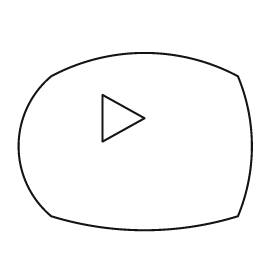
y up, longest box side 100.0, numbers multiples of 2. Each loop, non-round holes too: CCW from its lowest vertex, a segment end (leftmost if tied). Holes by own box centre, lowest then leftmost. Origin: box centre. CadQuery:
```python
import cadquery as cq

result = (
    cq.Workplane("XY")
    .moveTo(-36.0, -32.0)
    .threePointArc((4.0, -38.0), (44.0, -32.0))
    .threePointArc((50.0, -2.0), (44.0, 28.0))
    .threePointArc((4.0, 38.0), (-36.0, 28.0))
    .threePointArc((-50.0, -2.0), (-36.0, -32.0))
    .close()
    .moveTo(-14.0, 0.0)
    .lineTo(4.0, 10.0)
    .lineTo(-14.0, 20.0)
    .close()
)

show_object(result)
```